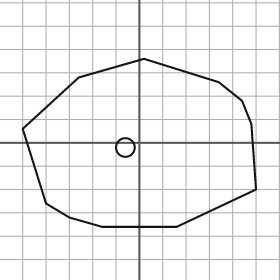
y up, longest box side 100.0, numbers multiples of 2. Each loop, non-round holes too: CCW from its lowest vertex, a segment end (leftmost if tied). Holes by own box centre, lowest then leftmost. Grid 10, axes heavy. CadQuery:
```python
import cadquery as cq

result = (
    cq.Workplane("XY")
    .moveTo(-16.0, -36.0)
    .lineTo(16.0, -36.0)
    .lineTo(50.0, -20.0)
    .lineTo(48.0, 8.0)
    .lineTo(44.0, 18.0)
    .lineTo(34.0, 26.0)
    .lineTo(2.0, 36.0)
    .lineTo(-26.0, 28.0)
    .lineTo(-50.0, 6.0)
    .lineTo(-40.0, -26.0)
    .lineTo(-30.0, -32.0)
    .close()
    .moveTo(-6.0, -2.0)
    .circle(4.0)
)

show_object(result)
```